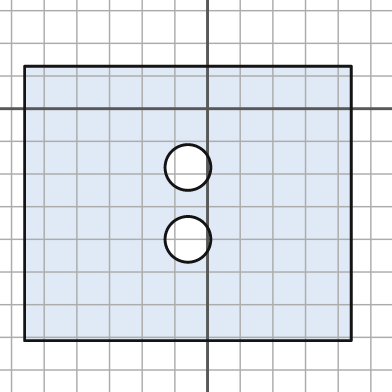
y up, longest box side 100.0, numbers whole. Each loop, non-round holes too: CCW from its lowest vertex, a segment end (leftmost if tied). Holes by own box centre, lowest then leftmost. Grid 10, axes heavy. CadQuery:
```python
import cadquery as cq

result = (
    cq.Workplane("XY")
    .moveTo(-56.0, -71.0)
    .lineTo(44.0, -71.0)
    .lineTo(44.0, 13.0)
    .lineTo(-56.0, 13.0)
    .close()
    .moveTo(-6.0, -40.0)
    .circle(7.0)
    .moveTo(-6.0, -18.0)
    .circle(7.0)
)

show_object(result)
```